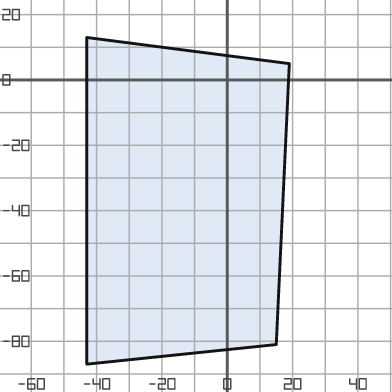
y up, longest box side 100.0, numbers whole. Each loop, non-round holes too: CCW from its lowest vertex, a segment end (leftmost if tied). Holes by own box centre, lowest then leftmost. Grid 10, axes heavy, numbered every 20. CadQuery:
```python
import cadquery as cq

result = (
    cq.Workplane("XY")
    .moveTo(-43.0, -87.0)
    .lineTo(15.0, -81.0)
    .lineTo(19.0, 5.0)
    .lineTo(-43.0, 13.0)
    .close()
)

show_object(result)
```